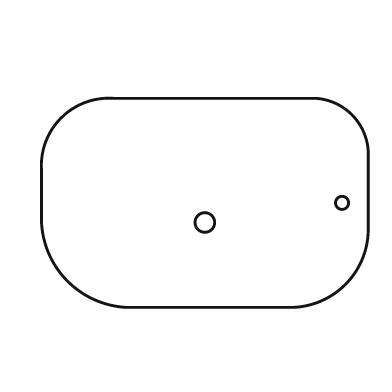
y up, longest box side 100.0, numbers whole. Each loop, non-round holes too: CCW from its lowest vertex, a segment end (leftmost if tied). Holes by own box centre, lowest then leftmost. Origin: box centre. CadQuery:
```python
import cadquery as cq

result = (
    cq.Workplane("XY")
    .moveTo(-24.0, -32.0)
    .lineTo(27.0, -32.0)
    .threePointArc((43.0, -25.0), (50.0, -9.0))
    .lineTo(50.0, 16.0)
    .threePointArc((45.0, 27.0), (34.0, 32.0))
    .lineTo(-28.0, 32.0)
    .threePointArc((-44.0, 26.0), (-50.0, 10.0))
    .lineTo(-50.0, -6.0)
    .threePointArc((-42.0, -24.0), (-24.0, -32.0))
    .close()
    .moveTo(0.0, -6.0)
    .circle(3.0)
    .moveTo(42.0, 0.0)
    .circle(2.0)
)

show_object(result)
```